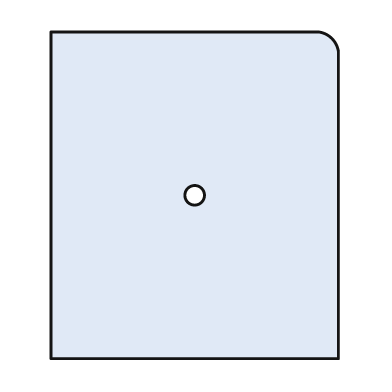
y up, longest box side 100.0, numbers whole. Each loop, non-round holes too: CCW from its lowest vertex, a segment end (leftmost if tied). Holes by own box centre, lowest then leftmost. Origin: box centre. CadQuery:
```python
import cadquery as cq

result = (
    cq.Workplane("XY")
    .moveTo(-44.0, -50.0)
    .lineTo(44.0, -50.0)
    .lineTo(44.0, 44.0)
    .threePointArc((42.0, 48.0), (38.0, 50.0))
    .lineTo(-44.0, 50.0)
    .close()
    .moveTo(0.0, 0.0)
    .circle(3.0)
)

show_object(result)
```